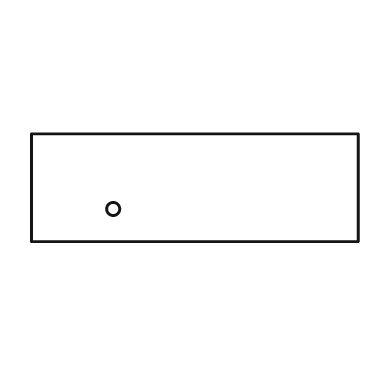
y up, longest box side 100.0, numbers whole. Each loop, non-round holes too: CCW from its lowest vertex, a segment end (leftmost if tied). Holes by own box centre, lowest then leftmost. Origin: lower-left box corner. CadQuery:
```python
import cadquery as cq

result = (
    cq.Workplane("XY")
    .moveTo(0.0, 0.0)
    .lineTo(100.0, 0.0)
    .lineTo(100.0, 33.0)
    .lineTo(0.0, 33.0)
    .close()
    .moveTo(25.0, 10.0)
    .circle(2.0)
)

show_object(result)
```